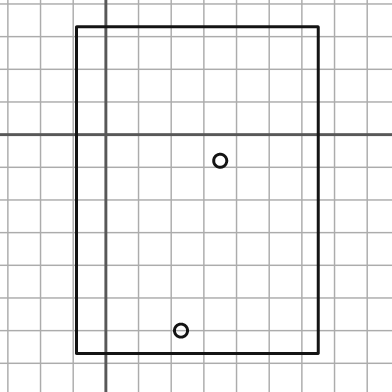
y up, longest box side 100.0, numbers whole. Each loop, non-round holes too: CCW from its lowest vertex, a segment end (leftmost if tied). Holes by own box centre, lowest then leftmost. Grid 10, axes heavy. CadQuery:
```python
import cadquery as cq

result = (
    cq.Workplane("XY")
    .moveTo(-9.0, -67.0)
    .lineTo(65.0, -67.0)
    .lineTo(65.0, 33.0)
    .lineTo(-9.0, 33.0)
    .close()
    .moveTo(23.0, -60.0)
    .circle(2.0)
    .moveTo(35.0, -8.0)
    .circle(2.0)
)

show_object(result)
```